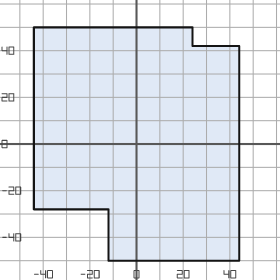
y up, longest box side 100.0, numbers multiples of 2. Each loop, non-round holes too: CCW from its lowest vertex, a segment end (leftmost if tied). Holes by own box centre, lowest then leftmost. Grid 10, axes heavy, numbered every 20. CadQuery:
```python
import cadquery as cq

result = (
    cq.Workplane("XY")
    .moveTo(-12.0, -50.0)
    .lineTo(44.0, -50.0)
    .lineTo(44.0, 42.0)
    .lineTo(24.0, 42.0)
    .lineTo(24.0, 50.0)
    .lineTo(-44.0, 50.0)
    .lineTo(-44.0, -28.0)
    .lineTo(-12.0, -28.0)
    .close()
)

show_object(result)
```